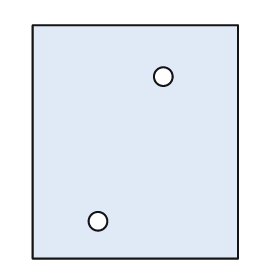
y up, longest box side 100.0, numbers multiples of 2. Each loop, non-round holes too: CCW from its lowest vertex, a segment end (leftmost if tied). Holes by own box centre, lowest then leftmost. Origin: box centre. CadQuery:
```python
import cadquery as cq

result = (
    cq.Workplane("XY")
    .moveTo(-44.0, -50.0)
    .lineTo(44.0, -50.0)
    .lineTo(44.0, 50.0)
    .lineTo(-44.0, 50.0)
    .close()
    .moveTo(-16.0, -34.0)
    .circle(4.0)
    .moveTo(12.0, 28.0)
    .circle(4.0)
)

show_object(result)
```